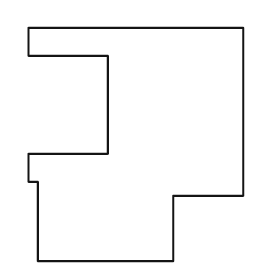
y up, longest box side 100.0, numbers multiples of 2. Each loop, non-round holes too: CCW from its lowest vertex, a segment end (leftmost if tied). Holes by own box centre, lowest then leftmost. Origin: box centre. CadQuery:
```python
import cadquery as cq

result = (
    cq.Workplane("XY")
    .moveTo(-42.0, -50.0)
    .lineTo(16.0, -50.0)
    .lineTo(16.0, -22.0)
    .lineTo(46.0, -22.0)
    .lineTo(46.0, 50.0)
    .lineTo(-46.0, 50.0)
    .lineTo(-46.0, 38.0)
    .lineTo(-12.0, 38.0)
    .lineTo(-12.0, -4.0)
    .lineTo(-46.0, -4.0)
    .lineTo(-46.0, -16.0)
    .lineTo(-42.0, -16.0)
    .close()
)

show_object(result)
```